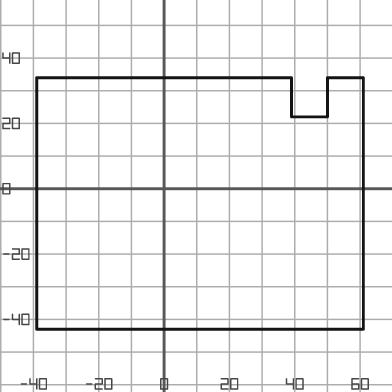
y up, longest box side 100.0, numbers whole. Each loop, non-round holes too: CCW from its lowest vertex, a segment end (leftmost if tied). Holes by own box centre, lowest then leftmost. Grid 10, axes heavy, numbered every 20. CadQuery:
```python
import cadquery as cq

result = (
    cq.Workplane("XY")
    .moveTo(-39.0, -43.0)
    .lineTo(61.0, -43.0)
    .lineTo(61.0, 34.0)
    .lineTo(50.0, 34.0)
    .lineTo(50.0, 22.0)
    .lineTo(39.0, 22.0)
    .lineTo(39.0, 34.0)
    .lineTo(-39.0, 34.0)
    .close()
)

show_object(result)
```